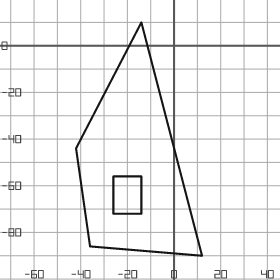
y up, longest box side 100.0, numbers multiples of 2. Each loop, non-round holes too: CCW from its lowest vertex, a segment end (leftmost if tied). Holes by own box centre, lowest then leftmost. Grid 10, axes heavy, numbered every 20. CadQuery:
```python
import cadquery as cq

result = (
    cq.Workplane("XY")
    .moveTo(12.0, -90.0)
    .lineTo(-14.0, 10.0)
    .lineTo(-42.0, -44.0)
    .lineTo(-36.0, -86.0)
    .close()
    .moveTo(-26.0, -72.0)
    .lineTo(-14.0, -72.0)
    .lineTo(-14.0, -56.0)
    .lineTo(-26.0, -56.0)
    .close()
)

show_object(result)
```